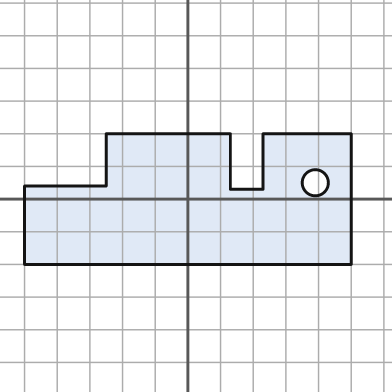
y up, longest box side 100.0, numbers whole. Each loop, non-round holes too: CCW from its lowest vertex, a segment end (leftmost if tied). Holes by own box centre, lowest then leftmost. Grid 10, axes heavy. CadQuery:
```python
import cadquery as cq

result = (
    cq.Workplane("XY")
    .moveTo(-50.0, -20.0)
    .lineTo(50.0, -20.0)
    .lineTo(50.0, 20.0)
    .lineTo(23.0, 20.0)
    .lineTo(23.0, 3.0)
    .lineTo(13.0, 3.0)
    .lineTo(13.0, 20.0)
    .lineTo(-25.0, 20.0)
    .lineTo(-25.0, 4.0)
    .lineTo(-50.0, 4.0)
    .close()
    .moveTo(39.0, 5.0)
    .circle(4.0)
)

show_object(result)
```